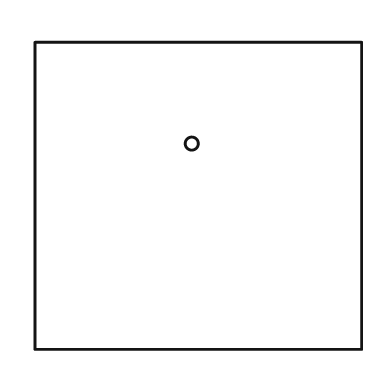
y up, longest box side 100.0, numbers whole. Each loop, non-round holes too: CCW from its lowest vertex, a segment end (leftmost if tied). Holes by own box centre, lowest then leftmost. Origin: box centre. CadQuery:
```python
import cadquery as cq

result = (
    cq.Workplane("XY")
    .moveTo(-50.0, -47.0)
    .lineTo(50.0, -47.0)
    .lineTo(50.0, 47.0)
    .lineTo(-50.0, 47.0)
    .close()
    .moveTo(-2.0, 16.0)
    .circle(2.0)
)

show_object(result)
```